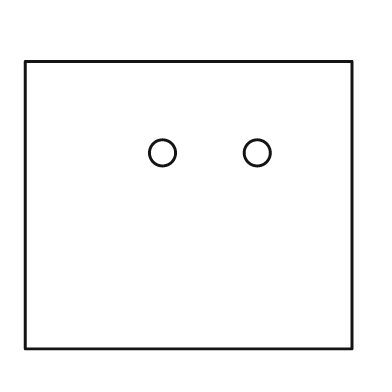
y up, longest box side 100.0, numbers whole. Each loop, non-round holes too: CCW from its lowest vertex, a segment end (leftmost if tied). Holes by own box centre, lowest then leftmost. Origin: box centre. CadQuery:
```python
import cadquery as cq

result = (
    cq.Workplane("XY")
    .moveTo(-50.0, -44.0)
    .lineTo(50.0, -44.0)
    .lineTo(50.0, 44.0)
    .lineTo(-50.0, 44.0)
    .close()
    .moveTo(-8.0, 16.0)
    .circle(4.0)
    .moveTo(21.0, 16.0)
    .circle(4.0)
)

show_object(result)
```